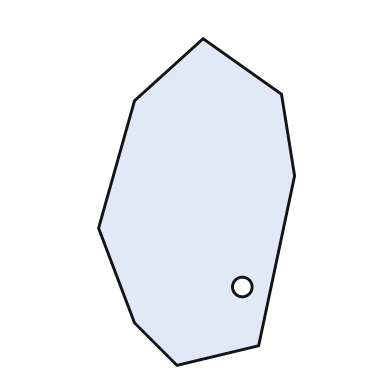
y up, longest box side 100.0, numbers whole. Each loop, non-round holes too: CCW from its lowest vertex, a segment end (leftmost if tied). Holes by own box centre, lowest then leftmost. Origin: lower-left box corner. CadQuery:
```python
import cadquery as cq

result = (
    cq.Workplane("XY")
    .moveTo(24.0, 0.0)
    .lineTo(49.0, 6.0)
    .lineTo(60.0, 58.0)
    .lineTo(56.0, 83.0)
    .lineTo(32.0, 100.0)
    .lineTo(11.0, 81.0)
    .lineTo(0.0, 42.0)
    .lineTo(11.0, 13.0)
    .close()
    .moveTo(44.0, 24.0)
    .circle(3.0)
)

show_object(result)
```